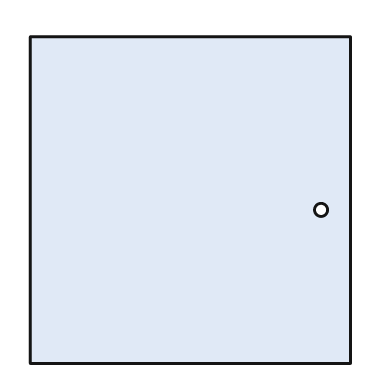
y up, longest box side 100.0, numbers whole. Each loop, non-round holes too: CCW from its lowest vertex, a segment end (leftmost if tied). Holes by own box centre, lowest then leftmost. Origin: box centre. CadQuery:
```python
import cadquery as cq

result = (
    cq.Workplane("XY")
    .moveTo(-49.0, -50.0)
    .lineTo(49.0, -50.0)
    .lineTo(49.0, 50.0)
    .lineTo(-49.0, 50.0)
    .close()
    .moveTo(40.0, -3.0)
    .circle(2.0)
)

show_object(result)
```